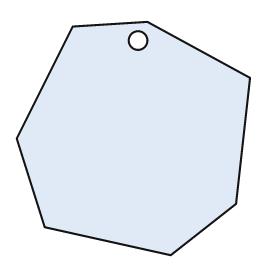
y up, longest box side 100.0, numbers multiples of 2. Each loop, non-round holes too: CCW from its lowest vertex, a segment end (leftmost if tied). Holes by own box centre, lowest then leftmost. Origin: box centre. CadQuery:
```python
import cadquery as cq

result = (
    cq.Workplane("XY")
    .moveTo(16.0, -50.0)
    .lineTo(44.0, -28.0)
    .lineTo(50.0, 26.0)
    .lineTo(6.0, 50.0)
    .lineTo(-26.0, 48.0)
    .lineTo(-50.0, 0.0)
    .lineTo(-38.0, -38.0)
    .close()
    .moveTo(2.0, 42.0)
    .circle(4.0)
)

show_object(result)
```